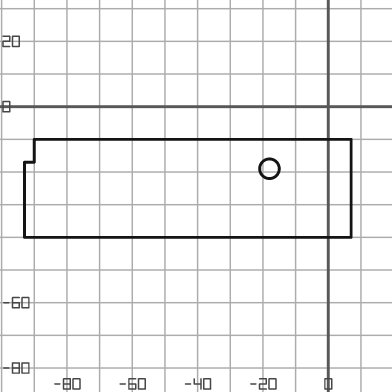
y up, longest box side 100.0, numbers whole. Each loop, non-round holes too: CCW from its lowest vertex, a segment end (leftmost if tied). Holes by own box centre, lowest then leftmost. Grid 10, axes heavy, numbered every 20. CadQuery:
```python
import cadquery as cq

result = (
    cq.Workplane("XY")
    .moveTo(-93.0, -40.0)
    .lineTo(7.0, -40.0)
    .lineTo(7.0, -10.0)
    .lineTo(-90.0, -10.0)
    .lineTo(-90.0, -17.0)
    .lineTo(-93.0, -17.0)
    .close()
    .moveTo(-18.0, -19.0)
    .circle(3.0)
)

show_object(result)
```